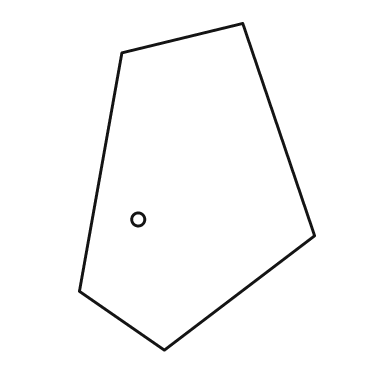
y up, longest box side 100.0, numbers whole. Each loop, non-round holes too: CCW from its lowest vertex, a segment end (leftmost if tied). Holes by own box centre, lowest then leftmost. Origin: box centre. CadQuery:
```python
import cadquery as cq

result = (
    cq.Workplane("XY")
    .moveTo(-10.0, -50.0)
    .lineTo(36.0, -15.0)
    .lineTo(14.0, 50.0)
    .lineTo(-23.0, 41.0)
    .lineTo(-36.0, -32.0)
    .close()
    .moveTo(-18.0, -10.0)
    .circle(2.0)
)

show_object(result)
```